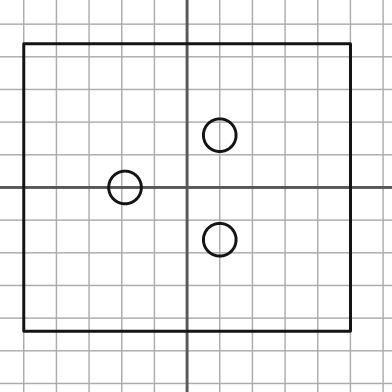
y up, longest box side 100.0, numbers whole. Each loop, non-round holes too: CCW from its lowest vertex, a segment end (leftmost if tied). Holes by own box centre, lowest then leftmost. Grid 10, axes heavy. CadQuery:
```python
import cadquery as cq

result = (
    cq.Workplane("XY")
    .moveTo(-50.0, -44.0)
    .lineTo(50.0, -44.0)
    .lineTo(50.0, 44.0)
    .lineTo(-50.0, 44.0)
    .close()
    .moveTo(10.0, -16.0)
    .circle(5.0)
    .moveTo(-19.0, 0.0)
    .circle(5.0)
    .moveTo(10.0, 16.0)
    .circle(5.0)
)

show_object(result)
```